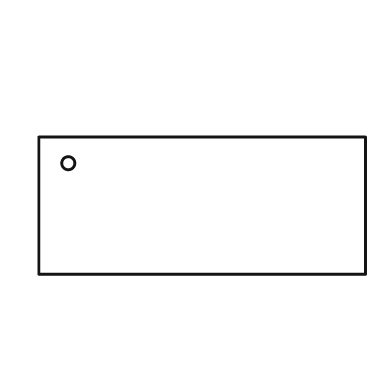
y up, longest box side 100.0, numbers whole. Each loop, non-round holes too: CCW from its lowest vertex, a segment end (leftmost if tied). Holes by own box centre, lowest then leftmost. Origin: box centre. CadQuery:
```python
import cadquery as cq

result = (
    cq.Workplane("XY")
    .moveTo(-50.0, -21.0)
    .lineTo(50.0, -21.0)
    .lineTo(50.0, 21.0)
    .lineTo(-50.0, 21.0)
    .close()
    .moveTo(-41.0, 13.0)
    .circle(2.0)
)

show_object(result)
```